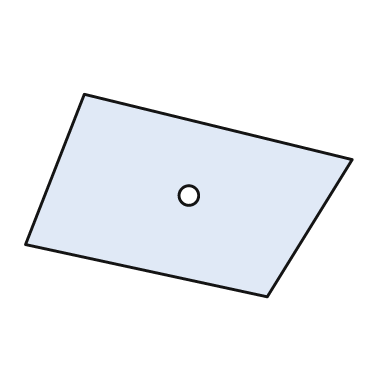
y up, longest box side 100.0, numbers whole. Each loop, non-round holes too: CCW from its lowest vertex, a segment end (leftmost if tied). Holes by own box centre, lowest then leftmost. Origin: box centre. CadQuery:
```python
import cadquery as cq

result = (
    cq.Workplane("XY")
    .moveTo(24.0, -31.0)
    .lineTo(50.0, 11.0)
    .lineTo(-32.0, 31.0)
    .lineTo(-50.0, -15.0)
    .close()
    .moveTo(0.0, 0.0)
    .circle(3.0)
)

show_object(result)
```